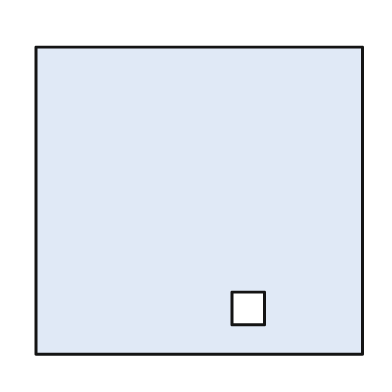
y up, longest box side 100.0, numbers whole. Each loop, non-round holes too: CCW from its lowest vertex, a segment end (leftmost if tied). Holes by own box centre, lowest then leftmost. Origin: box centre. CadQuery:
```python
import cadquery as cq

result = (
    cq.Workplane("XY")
    .moveTo(-50.0, -47.0)
    .lineTo(50.0, -47.0)
    .lineTo(50.0, 47.0)
    .lineTo(-50.0, 47.0)
    .close()
    .moveTo(10.0, -38.0)
    .lineTo(20.0, -38.0)
    .lineTo(20.0, -28.0)
    .lineTo(10.0, -28.0)
    .close()
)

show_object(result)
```